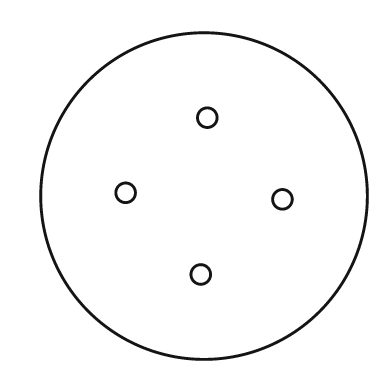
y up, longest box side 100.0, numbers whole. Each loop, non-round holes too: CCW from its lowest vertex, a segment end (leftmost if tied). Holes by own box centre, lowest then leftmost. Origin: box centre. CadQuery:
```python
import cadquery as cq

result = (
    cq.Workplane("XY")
    .moveTo(0.0, 0.0)
    .circle(50.0)
    .moveTo(-1.0, -24.0)
    .circle(3.0)
    .moveTo(24.0, -1.0)
    .circle(3.0)
    .moveTo(-24.0, 1.0)
    .circle(3.0)
    .moveTo(1.0, 24.0)
    .circle(3.0)
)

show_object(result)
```